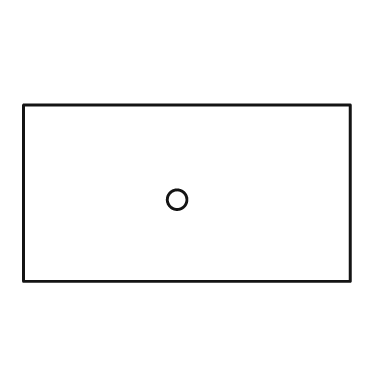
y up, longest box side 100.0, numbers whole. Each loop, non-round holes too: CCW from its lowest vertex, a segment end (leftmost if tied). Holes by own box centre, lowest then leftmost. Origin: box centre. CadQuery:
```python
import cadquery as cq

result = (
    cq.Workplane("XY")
    .moveTo(-50.0, -27.0)
    .lineTo(50.0, -27.0)
    .lineTo(50.0, 27.0)
    .lineTo(-50.0, 27.0)
    .close()
    .moveTo(-3.0, -2.0)
    .circle(3.0)
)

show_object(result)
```